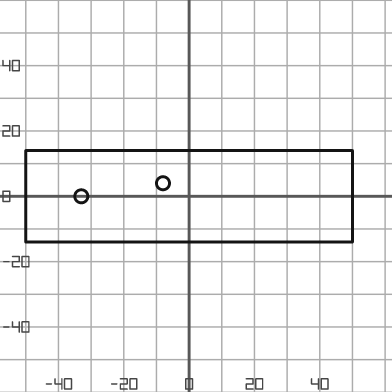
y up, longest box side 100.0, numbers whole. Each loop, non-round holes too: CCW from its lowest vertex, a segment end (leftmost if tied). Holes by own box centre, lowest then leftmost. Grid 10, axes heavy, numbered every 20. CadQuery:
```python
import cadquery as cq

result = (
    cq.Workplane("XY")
    .moveTo(-50.0, -14.0)
    .lineTo(50.0, -14.0)
    .lineTo(50.0, 14.0)
    .lineTo(-50.0, 14.0)
    .close()
    .moveTo(-33.0, 0.0)
    .circle(2.0)
    .moveTo(-8.0, 4.0)
    .circle(2.0)
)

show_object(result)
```